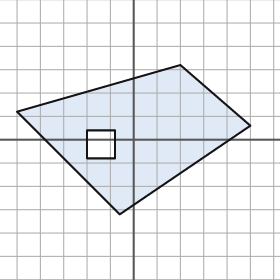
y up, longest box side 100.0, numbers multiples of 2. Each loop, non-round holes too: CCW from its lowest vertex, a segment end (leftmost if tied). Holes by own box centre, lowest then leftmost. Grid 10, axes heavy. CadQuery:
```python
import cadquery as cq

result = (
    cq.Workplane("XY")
    .moveTo(-6.0, -32.0)
    .lineTo(50.0, 6.0)
    .lineTo(20.0, 32.0)
    .lineTo(-50.0, 12.0)
    .close()
    .moveTo(-20.0, -8.0)
    .lineTo(-8.0, -8.0)
    .lineTo(-8.0, 4.0)
    .lineTo(-20.0, 4.0)
    .close()
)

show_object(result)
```